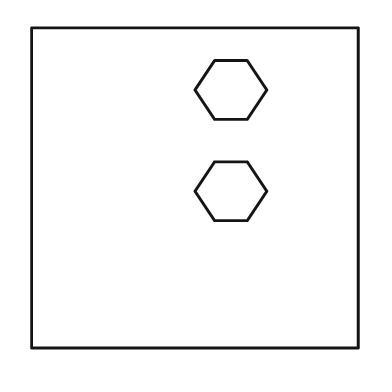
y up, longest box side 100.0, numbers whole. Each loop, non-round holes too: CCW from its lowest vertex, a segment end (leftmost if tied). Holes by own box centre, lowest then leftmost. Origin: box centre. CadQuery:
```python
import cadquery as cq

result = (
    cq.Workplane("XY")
    .moveTo(-50.0, -49.0)
    .lineTo(50.0, -49.0)
    .lineTo(50.0, 49.0)
    .lineTo(-50.0, 49.0)
    .close()
    .moveTo(6.0, -10.0)
    .lineTo(16.0, -10.0)
    .lineTo(22.0, -1.0)
    .lineTo(16.0, 8.0)
    .lineTo(6.0, 8.0)
    .lineTo(0.0, -1.0)
    .close()
    .moveTo(6.0, 21.0)
    .lineTo(16.0, 21.0)
    .lineTo(22.0, 30.0)
    .lineTo(16.0, 39.0)
    .lineTo(6.0, 39.0)
    .lineTo(0.0, 30.0)
    .close()
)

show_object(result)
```